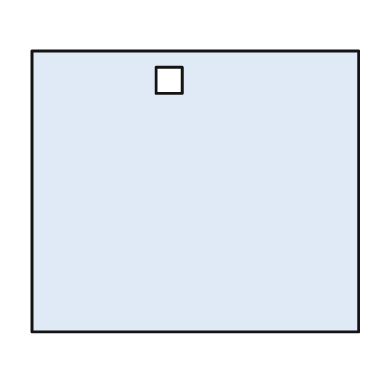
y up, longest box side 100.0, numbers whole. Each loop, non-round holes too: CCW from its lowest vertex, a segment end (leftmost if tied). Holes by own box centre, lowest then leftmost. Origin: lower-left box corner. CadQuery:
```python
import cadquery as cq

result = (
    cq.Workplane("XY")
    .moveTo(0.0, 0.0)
    .lineTo(100.0, 0.0)
    .lineTo(100.0, 86.0)
    .lineTo(0.0, 86.0)
    .close()
    .moveTo(38.0, 73.0)
    .lineTo(46.0, 73.0)
    .lineTo(46.0, 81.0)
    .lineTo(38.0, 81.0)
    .close()
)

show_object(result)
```